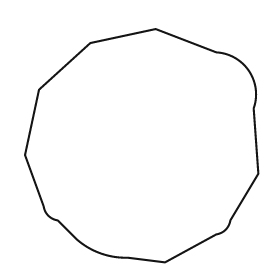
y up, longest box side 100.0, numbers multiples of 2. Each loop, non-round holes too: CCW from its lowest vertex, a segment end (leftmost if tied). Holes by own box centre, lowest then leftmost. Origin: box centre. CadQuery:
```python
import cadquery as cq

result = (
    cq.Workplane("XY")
    .moveTo(10.0, -50.0)
    .lineTo(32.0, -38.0)
    .threePointArc((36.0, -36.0), (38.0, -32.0))
    .lineTo(50.0, -12.0)
    .lineTo(48.0, 16.0)
    .threePointArc((46.0, 32.0), (32.0, 40.0))
    .lineTo(6.0, 50.0)
    .lineTo(-22.0, 44.0)
    .lineTo(-44.0, 24.0)
    .lineTo(-50.0, -4.0)
    .lineTo(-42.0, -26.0)
    .threePointArc((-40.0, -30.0), (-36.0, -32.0))
    .lineTo(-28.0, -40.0)
    .threePointArc((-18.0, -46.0), (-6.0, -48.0))
    .close()
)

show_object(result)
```